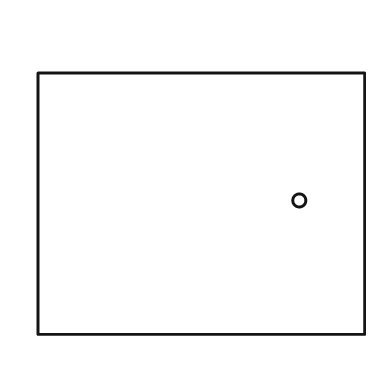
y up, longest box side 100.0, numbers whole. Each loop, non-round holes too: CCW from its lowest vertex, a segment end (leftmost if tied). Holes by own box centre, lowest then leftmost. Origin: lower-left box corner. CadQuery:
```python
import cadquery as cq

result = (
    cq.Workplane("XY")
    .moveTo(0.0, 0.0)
    .lineTo(100.0, 0.0)
    .lineTo(100.0, 80.0)
    .lineTo(0.0, 80.0)
    .close()
    .moveTo(80.0, 41.0)
    .circle(2.0)
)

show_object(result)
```